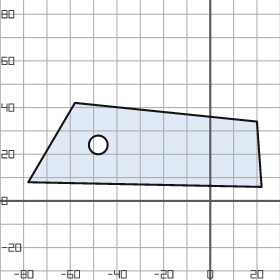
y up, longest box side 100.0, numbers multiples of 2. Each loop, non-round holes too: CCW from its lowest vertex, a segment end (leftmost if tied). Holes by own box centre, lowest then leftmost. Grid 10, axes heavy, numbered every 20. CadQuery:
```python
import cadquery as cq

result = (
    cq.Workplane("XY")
    .moveTo(22.0, 6.0)
    .lineTo(20.0, 34.0)
    .lineTo(-58.0, 42.0)
    .lineTo(-78.0, 8.0)
    .close()
    .moveTo(-48.0, 24.0)
    .circle(4.0)
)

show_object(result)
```